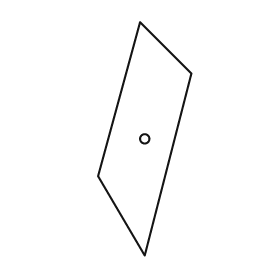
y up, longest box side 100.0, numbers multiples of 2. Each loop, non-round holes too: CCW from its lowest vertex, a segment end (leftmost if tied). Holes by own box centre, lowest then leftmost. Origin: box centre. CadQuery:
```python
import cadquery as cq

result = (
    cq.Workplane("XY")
    .moveTo(0.0, -50.0)
    .lineTo(20.0, 28.0)
    .lineTo(-2.0, 50.0)
    .lineTo(-20.0, -16.0)
    .close()
    .moveTo(0.0, 0.0)
    .circle(2.0)
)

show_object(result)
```